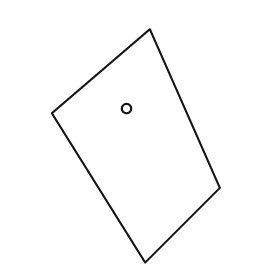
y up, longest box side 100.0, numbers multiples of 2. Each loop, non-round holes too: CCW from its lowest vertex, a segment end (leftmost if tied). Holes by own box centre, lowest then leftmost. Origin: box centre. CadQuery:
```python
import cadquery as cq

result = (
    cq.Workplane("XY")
    .moveTo(4.0, -50.0)
    .lineTo(36.0, -18.0)
    .lineTo(6.0, 50.0)
    .lineTo(-36.0, 14.0)
    .close()
    .moveTo(-4.0, 16.0)
    .circle(2.0)
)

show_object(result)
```